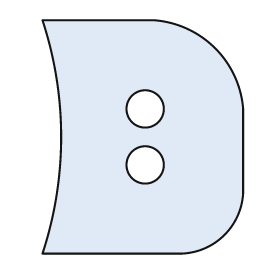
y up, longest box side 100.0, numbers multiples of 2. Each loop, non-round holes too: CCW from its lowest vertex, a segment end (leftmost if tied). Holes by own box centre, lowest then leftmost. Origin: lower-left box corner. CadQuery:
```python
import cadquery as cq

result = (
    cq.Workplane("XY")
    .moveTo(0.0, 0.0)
    .lineTo(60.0, 0.0)
    .threePointArc((78.0, 8.0), (86.0, 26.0))
    .lineTo(86.0, 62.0)
    .threePointArc((74.0, 88.0), (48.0, 100.0))
    .lineTo(0.0, 100.0)
    .threePointArc((8.0, 50.0), (0.0, 0.0))
    .close()
    .moveTo(44.0, 38.0)
    .circle(8.0)
    .moveTo(44.0, 62.0)
    .circle(8.0)
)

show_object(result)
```